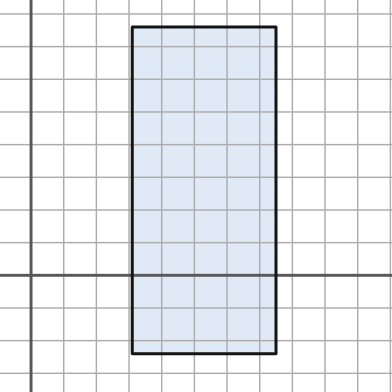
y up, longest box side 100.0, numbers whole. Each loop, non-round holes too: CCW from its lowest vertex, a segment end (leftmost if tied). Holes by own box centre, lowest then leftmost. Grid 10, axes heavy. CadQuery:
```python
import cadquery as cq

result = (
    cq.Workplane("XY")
    .moveTo(31.0, -24.0)
    .lineTo(75.0, -24.0)
    .lineTo(75.0, 76.0)
    .lineTo(31.0, 76.0)
    .close()
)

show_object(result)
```